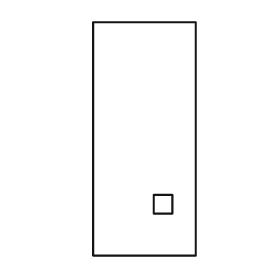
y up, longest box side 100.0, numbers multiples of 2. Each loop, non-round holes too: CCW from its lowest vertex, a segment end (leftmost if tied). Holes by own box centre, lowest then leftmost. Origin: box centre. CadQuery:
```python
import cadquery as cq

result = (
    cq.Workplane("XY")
    .moveTo(-22.0, -50.0)
    .lineTo(22.0, -50.0)
    .lineTo(22.0, 50.0)
    .lineTo(-22.0, 50.0)
    .close()
    .moveTo(4.0, -32.0)
    .lineTo(12.0, -32.0)
    .lineTo(12.0, -24.0)
    .lineTo(4.0, -24.0)
    .close()
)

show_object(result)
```